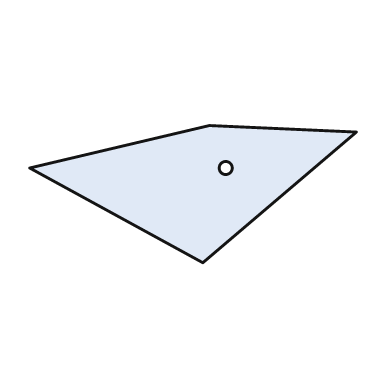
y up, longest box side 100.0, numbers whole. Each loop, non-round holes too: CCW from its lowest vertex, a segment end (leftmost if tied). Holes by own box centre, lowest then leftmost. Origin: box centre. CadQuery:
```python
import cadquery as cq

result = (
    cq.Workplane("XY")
    .moveTo(3.0, -21.0)
    .lineTo(50.0, 19.0)
    .lineTo(5.0, 21.0)
    .lineTo(-50.0, 8.0)
    .close()
    .moveTo(10.0, 8.0)
    .circle(2.0)
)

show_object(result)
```